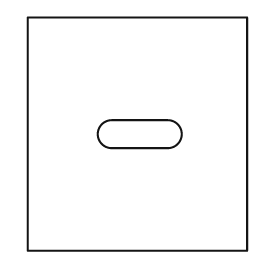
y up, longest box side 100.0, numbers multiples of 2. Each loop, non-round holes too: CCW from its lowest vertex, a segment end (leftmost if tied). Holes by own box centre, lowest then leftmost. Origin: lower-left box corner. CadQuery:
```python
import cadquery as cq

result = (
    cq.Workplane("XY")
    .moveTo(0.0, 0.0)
    .lineTo(94.0, 0.0)
    .lineTo(94.0, 100.0)
    .lineTo(0.0, 100.0)
    .close()
    .moveTo(36.0, 44.0)
    .lineTo(60.0, 44.0)
    .threePointArc((66.0, 50.0), (60.0, 56.0))
    .lineTo(36.0, 56.0)
    .threePointArc((30.0, 50.0), (36.0, 44.0))
    .close()
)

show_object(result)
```